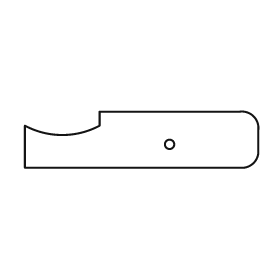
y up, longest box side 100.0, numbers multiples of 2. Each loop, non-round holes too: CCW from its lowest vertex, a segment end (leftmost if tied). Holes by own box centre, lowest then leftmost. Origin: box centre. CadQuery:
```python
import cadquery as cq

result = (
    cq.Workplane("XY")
    .moveTo(-50.0, -12.0)
    .lineTo(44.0, -12.0)
    .threePointArc((48.0, -10.0), (50.0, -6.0))
    .lineTo(50.0, 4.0)
    .threePointArc((48.0, 10.0), (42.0, 12.0))
    .lineTo(-18.0, 12.0)
    .lineTo(-18.0, 6.0)
    .threePointArc((-34.0, 2.0), (-50.0, 6.0))
    .close()
    .moveTo(12.0, -2.0)
    .circle(2.0)
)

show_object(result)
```